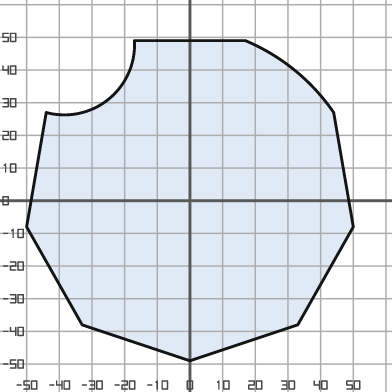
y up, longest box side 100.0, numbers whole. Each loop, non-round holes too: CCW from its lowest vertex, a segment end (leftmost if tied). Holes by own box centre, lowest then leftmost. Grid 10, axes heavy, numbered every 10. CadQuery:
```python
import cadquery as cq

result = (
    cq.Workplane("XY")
    .moveTo(0.0, -49.0)
    .lineTo(33.0, -38.0)
    .lineTo(50.0, -8.0)
    .lineTo(44.0, 27.0)
    .threePointArc((32.0, 40.0), (17.0, 49.0))
    .lineTo(-17.0, 49.0)
    .threePointArc((-25.0, 31.0), (-44.0, 27.0))
    .lineTo(-50.0, -8.0)
    .lineTo(-33.0, -38.0)
    .close()
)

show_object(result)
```